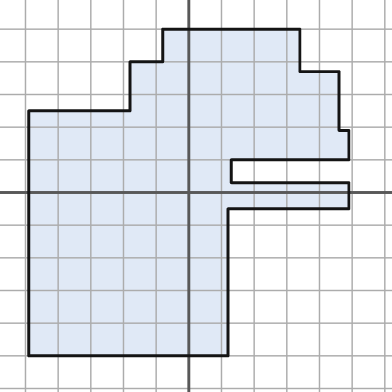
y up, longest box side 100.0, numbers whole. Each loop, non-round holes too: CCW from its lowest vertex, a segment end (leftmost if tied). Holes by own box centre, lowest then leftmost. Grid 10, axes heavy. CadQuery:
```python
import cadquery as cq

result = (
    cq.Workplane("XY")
    .moveTo(-49.0, -50.0)
    .lineTo(12.0, -50.0)
    .lineTo(12.0, -5.0)
    .lineTo(49.0, -5.0)
    .lineTo(49.0, 3.0)
    .lineTo(13.0, 3.0)
    .lineTo(13.0, 10.0)
    .lineTo(49.0, 10.0)
    .lineTo(49.0, 19.0)
    .lineTo(46.0, 19.0)
    .lineTo(46.0, 37.0)
    .lineTo(34.0, 37.0)
    .lineTo(34.0, 50.0)
    .lineTo(-8.0, 50.0)
    .lineTo(-8.0, 40.0)
    .lineTo(-18.0, 40.0)
    .lineTo(-18.0, 25.0)
    .lineTo(-49.0, 25.0)
    .close()
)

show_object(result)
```